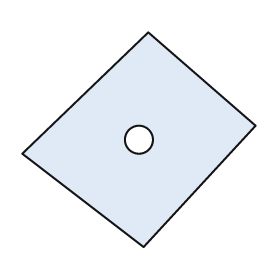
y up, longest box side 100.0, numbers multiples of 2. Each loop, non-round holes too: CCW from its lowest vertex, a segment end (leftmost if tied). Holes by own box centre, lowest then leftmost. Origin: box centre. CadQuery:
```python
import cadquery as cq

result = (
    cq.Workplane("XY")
    .moveTo(2.0, -46.0)
    .lineTo(50.0, 6.0)
    .lineTo(4.0, 46.0)
    .lineTo(-50.0, -6.0)
    .close()
    .moveTo(0.0, 0.0)
    .circle(6.0)
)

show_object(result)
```